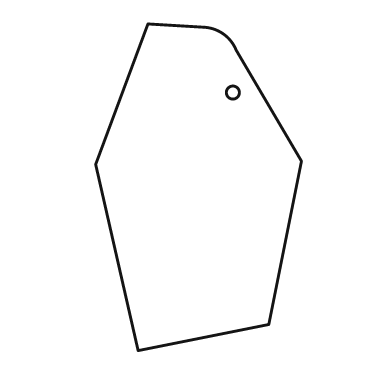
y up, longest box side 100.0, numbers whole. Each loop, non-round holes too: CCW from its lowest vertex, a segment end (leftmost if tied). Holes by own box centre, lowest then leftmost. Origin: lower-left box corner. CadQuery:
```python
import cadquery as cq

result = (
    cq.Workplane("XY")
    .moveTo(13.0, 0.0)
    .lineTo(53.0, 8.0)
    .lineTo(63.0, 58.0)
    .lineTo(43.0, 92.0)
    .threePointArc((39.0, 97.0), (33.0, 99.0))
    .lineTo(16.0, 100.0)
    .lineTo(0.0, 57.0)
    .close()
    .moveTo(42.0, 79.0)
    .circle(2.0)
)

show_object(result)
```